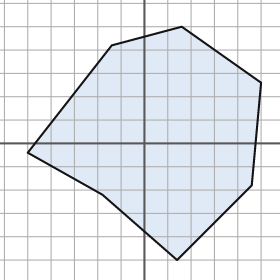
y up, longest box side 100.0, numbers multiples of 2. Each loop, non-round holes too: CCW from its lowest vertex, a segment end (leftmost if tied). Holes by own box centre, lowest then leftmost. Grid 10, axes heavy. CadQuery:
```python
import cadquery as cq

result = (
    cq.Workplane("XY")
    .moveTo(14.0, -50.0)
    .lineTo(46.0, -18.0)
    .lineTo(50.0, 26.0)
    .lineTo(16.0, 50.0)
    .lineTo(-14.0, 42.0)
    .lineTo(-50.0, -4.0)
    .lineTo(-18.0, -22.0)
    .close()
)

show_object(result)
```